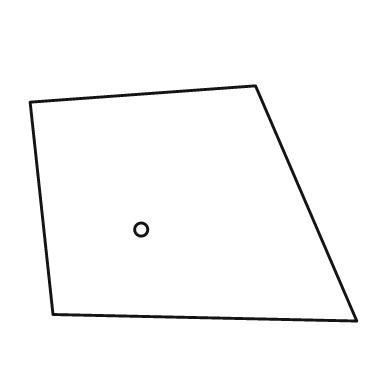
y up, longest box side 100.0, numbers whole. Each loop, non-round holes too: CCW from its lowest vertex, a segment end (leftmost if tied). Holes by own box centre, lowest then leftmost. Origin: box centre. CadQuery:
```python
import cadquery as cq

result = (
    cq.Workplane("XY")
    .moveTo(50.0, -36.0)
    .lineTo(19.0, 36.0)
    .lineTo(-50.0, 31.0)
    .lineTo(-43.0, -34.0)
    .close()
    .moveTo(-16.0, -8.0)
    .circle(2.0)
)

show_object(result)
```